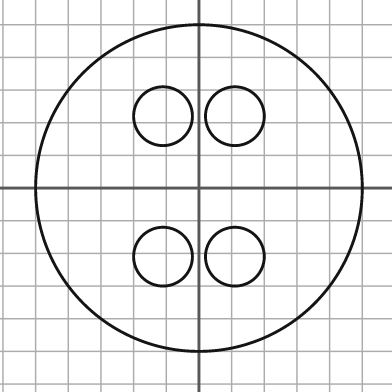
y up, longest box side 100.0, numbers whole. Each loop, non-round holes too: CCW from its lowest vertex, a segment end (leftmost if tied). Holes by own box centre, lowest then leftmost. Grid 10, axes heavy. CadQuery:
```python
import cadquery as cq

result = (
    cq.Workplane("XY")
    .moveTo(0.0, 0.0)
    .circle(50.0)
    .moveTo(-11.0, -21.0)
    .circle(9.0)
    .moveTo(11.0, -21.0)
    .circle(9.0)
    .moveTo(-11.0, 22.0)
    .circle(9.0)
    .moveTo(11.0, 22.0)
    .circle(9.0)
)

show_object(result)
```